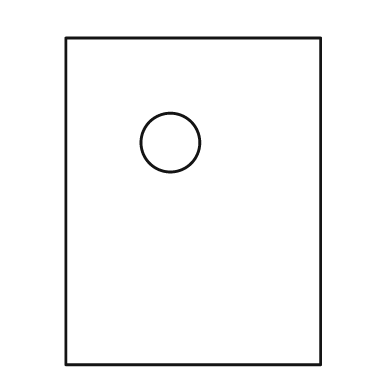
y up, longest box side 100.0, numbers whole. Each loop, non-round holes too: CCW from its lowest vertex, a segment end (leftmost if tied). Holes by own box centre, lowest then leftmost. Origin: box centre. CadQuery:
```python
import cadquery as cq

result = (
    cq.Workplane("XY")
    .moveTo(-39.0, -50.0)
    .lineTo(39.0, -50.0)
    .lineTo(39.0, 50.0)
    .lineTo(-39.0, 50.0)
    .close()
    .moveTo(-7.0, 18.0)
    .circle(9.0)
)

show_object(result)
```